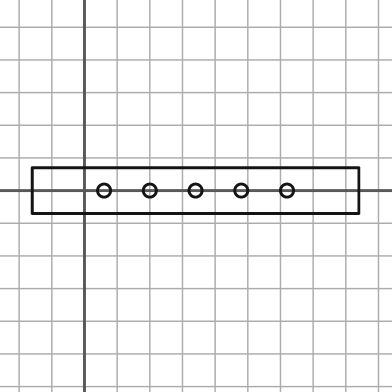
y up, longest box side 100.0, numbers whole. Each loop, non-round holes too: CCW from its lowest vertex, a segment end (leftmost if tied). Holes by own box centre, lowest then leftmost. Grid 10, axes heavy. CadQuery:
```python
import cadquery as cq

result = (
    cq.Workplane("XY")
    .moveTo(-16.0, -7.0)
    .lineTo(84.0, -7.0)
    .lineTo(84.0, 7.0)
    .lineTo(-16.0, 7.0)
    .close()
    .moveTo(6.0, 0.0)
    .circle(2.0)
    .moveTo(20.0, 0.0)
    .circle(2.0)
    .moveTo(34.0, 0.0)
    .circle(2.0)
    .moveTo(48.0, 0.0)
    .circle(2.0)
    .moveTo(62.0, 0.0)
    .circle(2.0)
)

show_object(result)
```